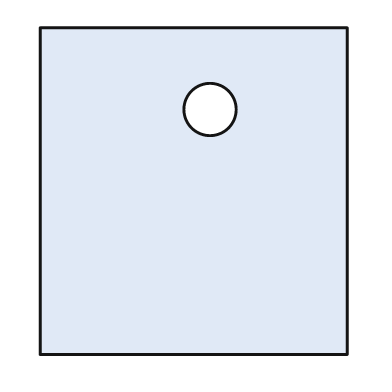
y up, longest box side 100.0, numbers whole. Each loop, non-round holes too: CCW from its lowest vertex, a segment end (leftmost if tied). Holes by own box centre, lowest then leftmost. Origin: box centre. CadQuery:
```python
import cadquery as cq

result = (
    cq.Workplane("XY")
    .moveTo(-47.0, -50.0)
    .lineTo(47.0, -50.0)
    .lineTo(47.0, 50.0)
    .lineTo(-47.0, 50.0)
    .close()
    .moveTo(5.0, 25.0)
    .circle(8.0)
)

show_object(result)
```